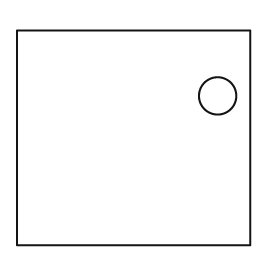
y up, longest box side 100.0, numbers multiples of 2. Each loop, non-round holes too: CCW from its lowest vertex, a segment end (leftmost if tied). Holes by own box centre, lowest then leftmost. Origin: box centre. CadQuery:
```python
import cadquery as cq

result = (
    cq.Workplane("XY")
    .moveTo(-50.0, -46.0)
    .lineTo(50.0, -46.0)
    .lineTo(50.0, 46.0)
    .lineTo(-50.0, 46.0)
    .close()
    .moveTo(36.0, 18.0)
    .circle(8.0)
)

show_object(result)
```